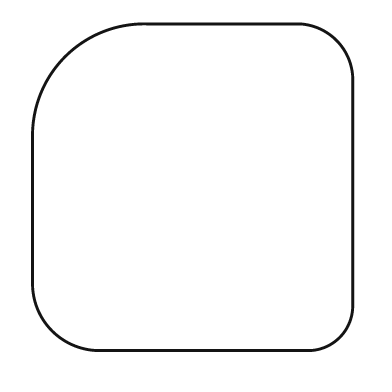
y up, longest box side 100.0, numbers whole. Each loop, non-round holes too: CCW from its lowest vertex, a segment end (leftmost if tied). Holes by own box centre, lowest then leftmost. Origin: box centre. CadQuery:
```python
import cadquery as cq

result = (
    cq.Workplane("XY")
    .moveTo(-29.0, -50.0)
    .lineTo(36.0, -50.0)
    .threePointArc((45.0, -46.0), (49.0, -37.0))
    .lineTo(49.0, 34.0)
    .threePointArc((44.0, 45.0), (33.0, 50.0))
    .lineTo(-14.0, 50.0)
    .threePointArc((-39.0, 40.0), (-49.0, 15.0))
    .lineTo(-49.0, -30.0)
    .threePointArc((-43.0, -44.0), (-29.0, -50.0))
    .close()
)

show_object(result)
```